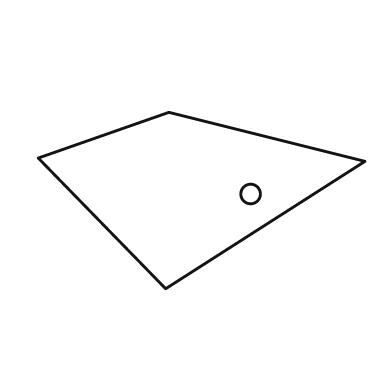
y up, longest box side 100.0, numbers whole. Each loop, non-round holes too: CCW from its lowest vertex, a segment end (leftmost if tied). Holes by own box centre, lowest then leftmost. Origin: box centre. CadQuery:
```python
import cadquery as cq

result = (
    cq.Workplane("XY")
    .moveTo(-11.0, -27.0)
    .lineTo(50.0, 12.0)
    .lineTo(-10.0, 27.0)
    .lineTo(-50.0, 13.0)
    .close()
    .moveTo(15.0, 2.0)
    .circle(3.0)
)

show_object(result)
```